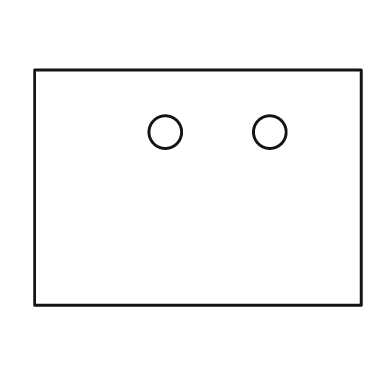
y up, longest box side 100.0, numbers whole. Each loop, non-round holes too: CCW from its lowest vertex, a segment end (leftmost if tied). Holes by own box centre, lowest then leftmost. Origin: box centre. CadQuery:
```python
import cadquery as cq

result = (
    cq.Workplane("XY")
    .moveTo(-50.0, -36.0)
    .lineTo(50.0, -36.0)
    .lineTo(50.0, 36.0)
    .lineTo(-50.0, 36.0)
    .close()
    .moveTo(-10.0, 17.0)
    .circle(5.0)
    .moveTo(22.0, 17.0)
    .circle(5.0)
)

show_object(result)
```